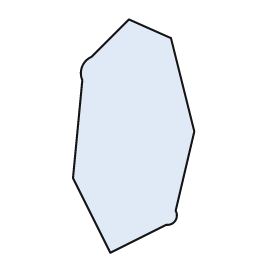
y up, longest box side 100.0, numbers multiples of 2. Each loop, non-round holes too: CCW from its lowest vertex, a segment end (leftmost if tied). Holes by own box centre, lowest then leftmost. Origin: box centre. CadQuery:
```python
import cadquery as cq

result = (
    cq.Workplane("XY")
    .moveTo(-10.0, -50.0)
    .lineTo(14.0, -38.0)
    .threePointArc((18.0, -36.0), (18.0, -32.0))
    .lineTo(26.0, 2.0)
    .lineTo(16.0, 42.0)
    .lineTo(-2.0, 50.0)
    .lineTo(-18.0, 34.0)
    .threePointArc((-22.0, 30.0), (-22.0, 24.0))
    .lineTo(-26.0, -18.0)
    .close()
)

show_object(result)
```